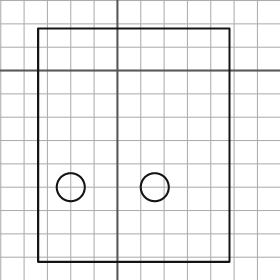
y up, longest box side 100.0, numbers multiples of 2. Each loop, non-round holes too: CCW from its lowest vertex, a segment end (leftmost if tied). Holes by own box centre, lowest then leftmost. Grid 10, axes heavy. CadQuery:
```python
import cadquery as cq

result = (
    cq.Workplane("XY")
    .moveTo(-34.0, -82.0)
    .lineTo(48.0, -82.0)
    .lineTo(48.0, 18.0)
    .lineTo(-34.0, 18.0)
    .close()
    .moveTo(-20.0, -50.0)
    .circle(6.0)
    .moveTo(16.0, -50.0)
    .circle(6.0)
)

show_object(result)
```